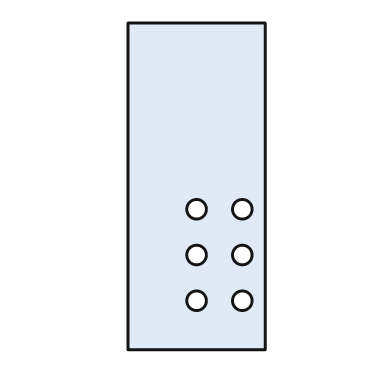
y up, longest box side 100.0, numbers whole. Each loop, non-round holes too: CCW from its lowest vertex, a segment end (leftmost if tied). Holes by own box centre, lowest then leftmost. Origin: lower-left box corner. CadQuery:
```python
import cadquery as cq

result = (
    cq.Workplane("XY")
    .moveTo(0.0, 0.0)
    .lineTo(42.0, 0.0)
    .lineTo(42.0, 100.0)
    .lineTo(0.0, 100.0)
    .close()
    .moveTo(21.0, 15.0)
    .circle(3.0)
    .moveTo(35.0, 15.0)
    .circle(3.0)
    .moveTo(21.0, 29.0)
    .circle(3.0)
    .moveTo(35.0, 29.0)
    .circle(3.0)
    .moveTo(21.0, 43.0)
    .circle(3.0)
    .moveTo(35.0, 43.0)
    .circle(3.0)
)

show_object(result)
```